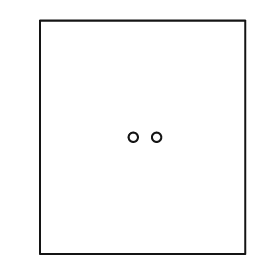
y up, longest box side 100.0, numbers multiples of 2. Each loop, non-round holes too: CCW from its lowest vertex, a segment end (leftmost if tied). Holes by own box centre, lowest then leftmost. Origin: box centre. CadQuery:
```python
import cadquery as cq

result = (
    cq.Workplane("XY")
    .moveTo(-44.0, -50.0)
    .lineTo(44.0, -50.0)
    .lineTo(44.0, 50.0)
    .lineTo(-44.0, 50.0)
    .close()
    .moveTo(-4.0, 0.0)
    .circle(2.0)
    .moveTo(6.0, 0.0)
    .circle(2.0)
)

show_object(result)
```